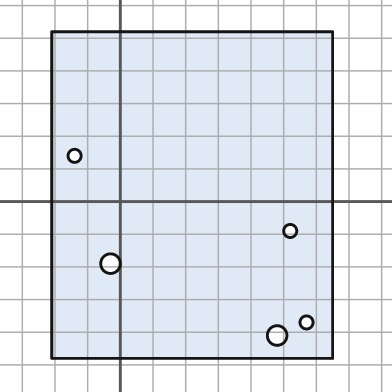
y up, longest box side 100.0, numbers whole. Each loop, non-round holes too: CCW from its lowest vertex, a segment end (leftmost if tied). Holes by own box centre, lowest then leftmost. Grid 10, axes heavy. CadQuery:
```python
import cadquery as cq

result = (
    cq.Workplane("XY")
    .moveTo(-21.0, -48.0)
    .lineTo(65.0, -48.0)
    .lineTo(65.0, 52.0)
    .lineTo(-21.0, 52.0)
    .close()
    .moveTo(48.0, -41.0)
    .circle(3.0)
    .moveTo(57.0, -37.0)
    .circle(2.0)
    .moveTo(-3.0, -19.0)
    .circle(3.0)
    .moveTo(52.0, -9.0)
    .circle(2.0)
    .moveTo(-14.0, 14.0)
    .circle(2.0)
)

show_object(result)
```